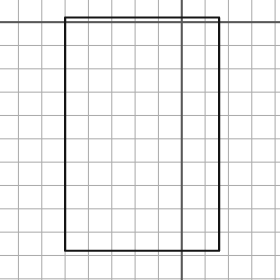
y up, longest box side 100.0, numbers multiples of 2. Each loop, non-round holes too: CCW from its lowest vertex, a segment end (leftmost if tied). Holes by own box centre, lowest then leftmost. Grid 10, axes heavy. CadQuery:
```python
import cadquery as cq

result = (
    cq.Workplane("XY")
    .moveTo(-50.0, -98.0)
    .lineTo(16.0, -98.0)
    .lineTo(16.0, 2.0)
    .lineTo(-50.0, 2.0)
    .close()
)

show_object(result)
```